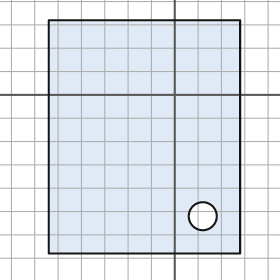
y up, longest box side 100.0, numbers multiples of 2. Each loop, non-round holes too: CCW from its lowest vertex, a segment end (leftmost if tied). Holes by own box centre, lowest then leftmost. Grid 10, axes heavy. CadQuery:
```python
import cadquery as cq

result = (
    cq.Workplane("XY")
    .moveTo(-54.0, -68.0)
    .lineTo(28.0, -68.0)
    .lineTo(28.0, 32.0)
    .lineTo(-54.0, 32.0)
    .close()
    .moveTo(12.0, -52.0)
    .circle(6.0)
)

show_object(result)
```